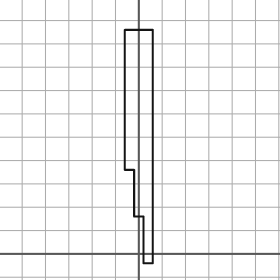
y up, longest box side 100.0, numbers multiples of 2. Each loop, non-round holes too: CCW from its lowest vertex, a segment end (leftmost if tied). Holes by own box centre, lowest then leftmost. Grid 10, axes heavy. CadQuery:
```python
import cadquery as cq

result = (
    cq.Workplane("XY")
    .moveTo(2.0, -4.0)
    .lineTo(6.0, -4.0)
    .lineTo(6.0, 96.0)
    .lineTo(-6.0, 96.0)
    .lineTo(-6.0, 36.0)
    .lineTo(-2.0, 36.0)
    .lineTo(-2.0, 16.0)
    .lineTo(2.0, 16.0)
    .close()
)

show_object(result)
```